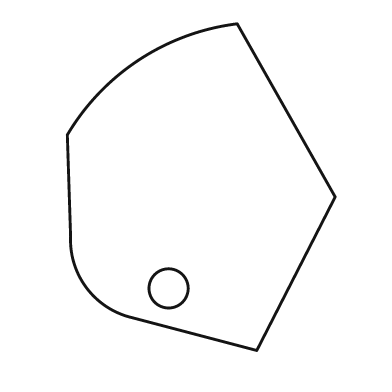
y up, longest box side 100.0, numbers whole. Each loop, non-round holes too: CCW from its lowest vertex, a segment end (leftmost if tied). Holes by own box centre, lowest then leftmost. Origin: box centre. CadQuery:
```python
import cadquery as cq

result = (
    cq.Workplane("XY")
    .moveTo(17.0, -50.0)
    .lineTo(41.0, -3.0)
    .lineTo(11.0, 50.0)
    .threePointArc((-19.0, 39.0), (-41.0, 16.0))
    .lineTo(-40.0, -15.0)
    .threePointArc((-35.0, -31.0), (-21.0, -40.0))
    .close()
    .moveTo(-10.0, -31.0)
    .circle(6.0)
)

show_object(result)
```